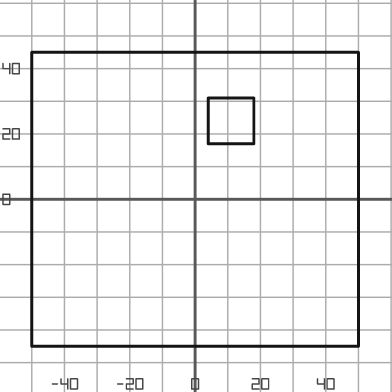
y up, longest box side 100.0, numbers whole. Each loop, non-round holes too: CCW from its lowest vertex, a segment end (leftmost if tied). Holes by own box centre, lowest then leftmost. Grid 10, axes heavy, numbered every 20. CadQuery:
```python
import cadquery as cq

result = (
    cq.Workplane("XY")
    .moveTo(-50.0, -45.0)
    .lineTo(50.0, -45.0)
    .lineTo(50.0, 45.0)
    .lineTo(-50.0, 45.0)
    .close()
    .moveTo(4.0, 17.0)
    .lineTo(18.0, 17.0)
    .lineTo(18.0, 31.0)
    .lineTo(4.0, 31.0)
    .close()
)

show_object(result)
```